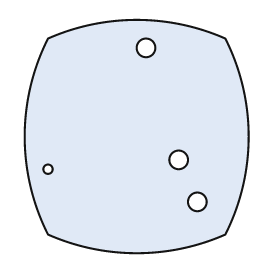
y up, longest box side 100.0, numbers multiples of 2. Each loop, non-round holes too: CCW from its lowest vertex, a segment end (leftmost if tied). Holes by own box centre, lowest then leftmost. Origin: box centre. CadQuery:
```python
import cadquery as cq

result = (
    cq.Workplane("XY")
    .moveTo(-38.0, -42.0)
    .threePointArc((0.0, -50.0), (38.0, -42.0))
    .threePointArc((48.0, 0.0), (38.0, 42.0))
    .threePointArc((0.0, 50.0), (-38.0, 42.0))
    .threePointArc((-48.0, 0.0), (-38.0, -42.0))
    .close()
    .moveTo(26.0, -28.0)
    .circle(4.0)
    .moveTo(-38.0, -14.0)
    .circle(2.0)
    .moveTo(18.0, -10.0)
    .circle(4.0)
    .moveTo(4.0, 38.0)
    .circle(4.0)
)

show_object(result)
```